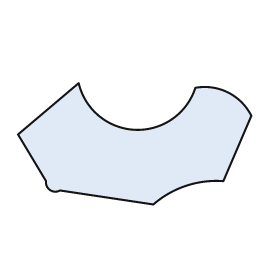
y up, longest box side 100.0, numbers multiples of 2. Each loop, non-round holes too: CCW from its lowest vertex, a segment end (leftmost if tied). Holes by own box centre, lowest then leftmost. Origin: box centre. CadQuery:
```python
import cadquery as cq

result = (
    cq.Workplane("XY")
    .moveTo(8.0, -26.0)
    .threePointArc((22.0, -18.0), (38.0, -16.0))
    .lineTo(50.0, 12.0)
    .threePointArc((40.0, 22.0), (26.0, 24.0))
    .threePointArc((0.0, 6.0), (-24.0, 26.0))
    .lineTo(-50.0, 4.0)
    .lineTo(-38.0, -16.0)
    .threePointArc((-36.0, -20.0), (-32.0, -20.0))
    .close()
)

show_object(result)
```